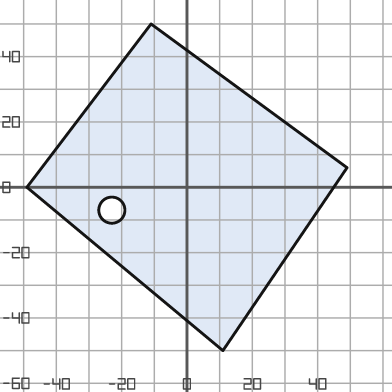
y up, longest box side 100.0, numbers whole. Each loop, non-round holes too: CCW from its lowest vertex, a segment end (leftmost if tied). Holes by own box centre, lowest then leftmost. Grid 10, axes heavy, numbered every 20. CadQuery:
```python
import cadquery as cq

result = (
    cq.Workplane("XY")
    .moveTo(11.0, -50.0)
    .lineTo(49.0, 6.0)
    .lineTo(-11.0, 50.0)
    .lineTo(-49.0, 0.0)
    .close()
    .moveTo(-23.0, -7.0)
    .circle(4.0)
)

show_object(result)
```